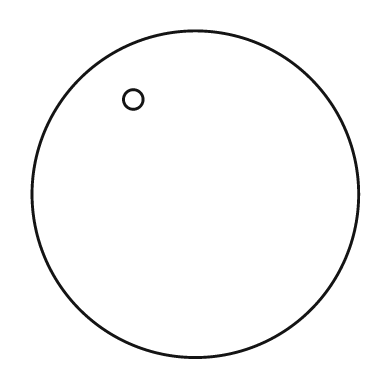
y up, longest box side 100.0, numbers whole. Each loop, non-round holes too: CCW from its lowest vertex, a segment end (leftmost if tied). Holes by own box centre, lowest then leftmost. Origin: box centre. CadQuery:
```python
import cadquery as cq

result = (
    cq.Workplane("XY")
    .moveTo(0.0, 0.0)
    .circle(50.0)
    .moveTo(-19.0, 29.0)
    .circle(3.0)
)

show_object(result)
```